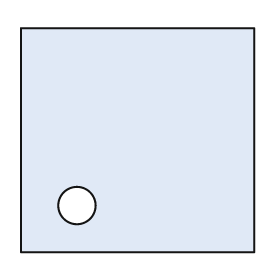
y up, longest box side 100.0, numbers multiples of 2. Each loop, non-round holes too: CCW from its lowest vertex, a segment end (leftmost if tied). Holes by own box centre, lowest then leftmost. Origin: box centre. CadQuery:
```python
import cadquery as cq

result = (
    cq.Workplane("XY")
    .moveTo(-50.0, -48.0)
    .lineTo(50.0, -48.0)
    .lineTo(50.0, 48.0)
    .lineTo(-50.0, 48.0)
    .close()
    .moveTo(-26.0, -28.0)
    .circle(8.0)
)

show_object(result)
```